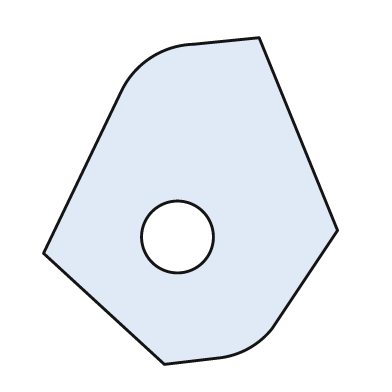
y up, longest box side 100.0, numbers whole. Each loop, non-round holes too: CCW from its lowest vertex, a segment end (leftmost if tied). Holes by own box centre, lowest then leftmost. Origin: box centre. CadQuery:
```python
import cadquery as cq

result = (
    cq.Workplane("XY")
    .moveTo(-8.0, -50.0)
    .lineTo(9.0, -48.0)
    .threePointArc((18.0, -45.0), (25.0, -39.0))
    .lineTo(45.0, -9.0)
    .lineTo(21.0, 50.0)
    .lineTo(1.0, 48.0)
    .threePointArc((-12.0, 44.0), (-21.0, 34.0))
    .lineTo(-45.0, -16.0)
    .close()
    .moveTo(-4.0, -11.0)
    .circle(11.0)
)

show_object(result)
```